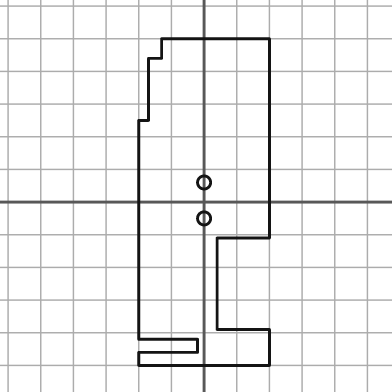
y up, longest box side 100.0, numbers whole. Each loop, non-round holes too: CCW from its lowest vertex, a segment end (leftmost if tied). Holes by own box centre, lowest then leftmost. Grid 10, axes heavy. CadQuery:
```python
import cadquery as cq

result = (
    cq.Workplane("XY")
    .moveTo(-20.0, -50.0)
    .lineTo(20.0, -50.0)
    .lineTo(20.0, -39.0)
    .lineTo(4.0, -39.0)
    .lineTo(4.0, -11.0)
    .lineTo(20.0, -11.0)
    .lineTo(20.0, 50.0)
    .lineTo(-13.0, 50.0)
    .lineTo(-13.0, 44.0)
    .lineTo(-17.0, 44.0)
    .lineTo(-17.0, 25.0)
    .lineTo(-20.0, 25.0)
    .lineTo(-20.0, -42.0)
    .lineTo(-2.0, -42.0)
    .lineTo(-2.0, -46.0)
    .lineTo(-20.0, -46.0)
    .close()
    .moveTo(0.0, -5.0)
    .circle(2.0)
    .moveTo(0.0, 6.0)
    .circle(2.0)
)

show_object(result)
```